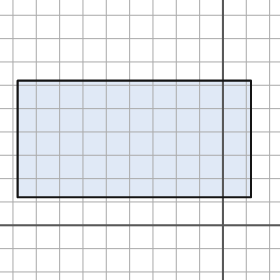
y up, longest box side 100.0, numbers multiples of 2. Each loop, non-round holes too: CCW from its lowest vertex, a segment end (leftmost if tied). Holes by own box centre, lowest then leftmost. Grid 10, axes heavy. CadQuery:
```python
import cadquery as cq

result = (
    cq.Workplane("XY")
    .moveTo(-88.0, 12.0)
    .lineTo(12.0, 12.0)
    .lineTo(12.0, 62.0)
    .lineTo(-88.0, 62.0)
    .close()
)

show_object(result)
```